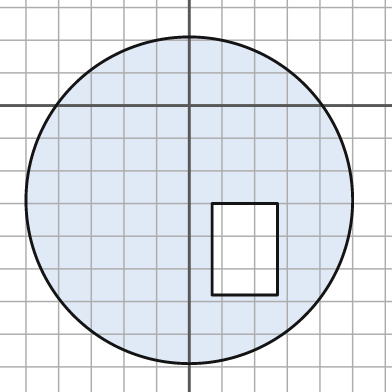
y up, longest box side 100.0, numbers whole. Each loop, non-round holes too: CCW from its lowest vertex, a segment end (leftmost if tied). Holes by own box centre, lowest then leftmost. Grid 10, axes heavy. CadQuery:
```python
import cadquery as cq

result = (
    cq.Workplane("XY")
    .moveTo(0.0, -29.0)
    .circle(50.0)
    .moveTo(7.0, -58.0)
    .lineTo(27.0, -58.0)
    .lineTo(27.0, -30.0)
    .lineTo(7.0, -30.0)
    .close()
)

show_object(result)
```